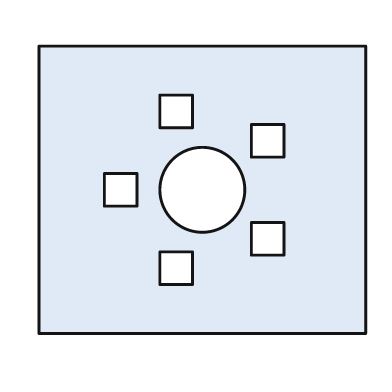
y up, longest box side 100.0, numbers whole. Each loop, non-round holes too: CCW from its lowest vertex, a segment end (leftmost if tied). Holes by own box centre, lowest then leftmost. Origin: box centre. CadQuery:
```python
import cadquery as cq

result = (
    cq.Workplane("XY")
    .moveTo(-50.0, -44.0)
    .lineTo(50.0, -44.0)
    .lineTo(50.0, 44.0)
    .lineTo(-50.0, 44.0)
    .close()
    .moveTo(-13.0, -29.0)
    .lineTo(-3.0, -29.0)
    .lineTo(-3.0, -19.0)
    .lineTo(-13.0, -19.0)
    .close()
    .moveTo(15.0, -20.0)
    .lineTo(25.0, -20.0)
    .lineTo(25.0, -10.0)
    .lineTo(15.0, -10.0)
    .close()
    .moveTo(-30.0, -5.0)
    .lineTo(-20.0, -5.0)
    .lineTo(-20.0, 5.0)
    .lineTo(-30.0, 5.0)
    .close()
    .moveTo(0.0, 0.0)
    .circle(13.0)
    .moveTo(15.0, 10.0)
    .lineTo(25.0, 10.0)
    .lineTo(25.0, 20.0)
    .lineTo(15.0, 20.0)
    .close()
    .moveTo(-13.0, 19.0)
    .lineTo(-3.0, 19.0)
    .lineTo(-3.0, 29.0)
    .lineTo(-13.0, 29.0)
    .close()
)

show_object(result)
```